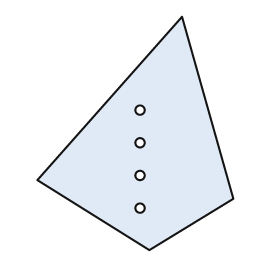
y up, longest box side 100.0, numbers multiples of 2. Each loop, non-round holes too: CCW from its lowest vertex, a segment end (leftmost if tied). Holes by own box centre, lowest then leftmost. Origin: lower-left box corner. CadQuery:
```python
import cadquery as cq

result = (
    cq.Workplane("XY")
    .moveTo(48.0, 0.0)
    .lineTo(84.0, 22.0)
    .lineTo(62.0, 100.0)
    .lineTo(0.0, 30.0)
    .close()
    .moveTo(44.0, 18.0)
    .circle(2.0)
    .moveTo(44.0, 32.0)
    .circle(2.0)
    .moveTo(44.0, 46.0)
    .circle(2.0)
    .moveTo(44.0, 60.0)
    .circle(2.0)
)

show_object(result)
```